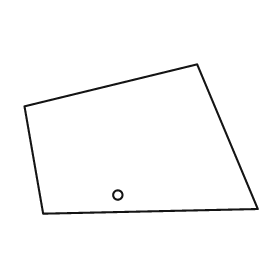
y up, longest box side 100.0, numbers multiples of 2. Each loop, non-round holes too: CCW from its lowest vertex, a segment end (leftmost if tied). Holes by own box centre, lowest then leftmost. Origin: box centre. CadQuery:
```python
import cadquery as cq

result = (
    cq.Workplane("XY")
    .moveTo(-42.0, -32.0)
    .lineTo(50.0, -30.0)
    .lineTo(24.0, 32.0)
    .lineTo(-50.0, 14.0)
    .close()
    .moveTo(-10.0, -24.0)
    .circle(2.0)
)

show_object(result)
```